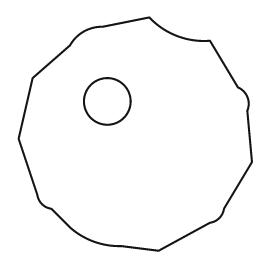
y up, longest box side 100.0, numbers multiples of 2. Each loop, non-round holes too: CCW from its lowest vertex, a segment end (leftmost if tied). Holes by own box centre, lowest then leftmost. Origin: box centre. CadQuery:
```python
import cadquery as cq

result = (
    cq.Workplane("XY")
    .moveTo(10.0, -50.0)
    .lineTo(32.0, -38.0)
    .threePointArc((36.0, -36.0), (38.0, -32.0))
    .lineTo(50.0, -12.0)
    .lineTo(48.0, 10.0)
    .threePointArc((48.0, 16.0), (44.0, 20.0))
    .lineTo(32.0, 40.0)
    .threePointArc((18.0, 42.0), (6.0, 50.0))
    .lineTo(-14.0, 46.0)
    .threePointArc((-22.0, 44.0), (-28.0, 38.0))
    .lineTo(-44.0, 24.0)
    .lineTo(-50.0, -2.0)
    .lineTo(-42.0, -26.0)
    .threePointArc((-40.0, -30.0), (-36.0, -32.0))
    .lineTo(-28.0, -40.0)
    .threePointArc((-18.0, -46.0), (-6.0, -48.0))
    .close()
    .moveTo(-12.0, 14.0)
    .circle(10.0)
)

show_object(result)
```